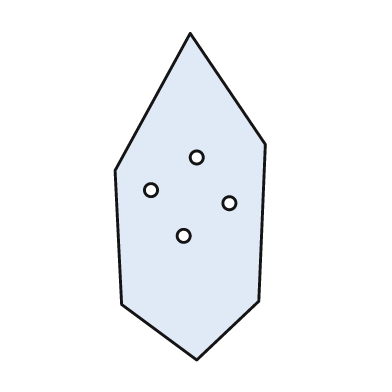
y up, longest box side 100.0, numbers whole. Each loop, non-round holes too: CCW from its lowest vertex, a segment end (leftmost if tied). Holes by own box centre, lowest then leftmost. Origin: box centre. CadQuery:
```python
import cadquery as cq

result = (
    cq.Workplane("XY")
    .moveTo(2.0, -50.0)
    .lineTo(21.0, -32.0)
    .lineTo(23.0, 16.0)
    .lineTo(0.0, 50.0)
    .lineTo(-23.0, 8.0)
    .lineTo(-21.0, -33.0)
    .close()
    .moveTo(-2.0, -12.0)
    .circle(2.0)
    .moveTo(12.0, -2.0)
    .circle(2.0)
    .moveTo(-12.0, 2.0)
    .circle(2.0)
    .moveTo(2.0, 12.0)
    .circle(2.0)
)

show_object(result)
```